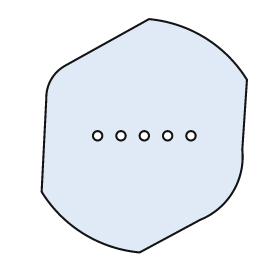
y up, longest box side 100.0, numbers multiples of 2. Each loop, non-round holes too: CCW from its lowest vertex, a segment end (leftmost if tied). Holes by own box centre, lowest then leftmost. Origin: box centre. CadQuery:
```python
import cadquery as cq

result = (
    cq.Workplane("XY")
    .moveTo(-2.0, -50.0)
    .lineTo(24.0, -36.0)
    .threePointArc((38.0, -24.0), (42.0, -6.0))
    .lineTo(44.0, 24.0)
    .threePointArc((26.0, 42.0), (2.0, 50.0))
    .lineTo(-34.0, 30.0)
    .threePointArc((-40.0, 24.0), (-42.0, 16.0))
    .lineTo(-44.0, -24.0)
    .threePointArc((-26.0, -42.0), (-2.0, -50.0))
    .close()
    .moveTo(-20.0, 0.0)
    .circle(2.0)
    .moveTo(-10.0, 0.0)
    .circle(2.0)
    .moveTo(0.0, 0.0)
    .circle(2.0)
    .moveTo(10.0, 0.0)
    .circle(2.0)
    .moveTo(20.0, 0.0)
    .circle(2.0)
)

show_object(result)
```